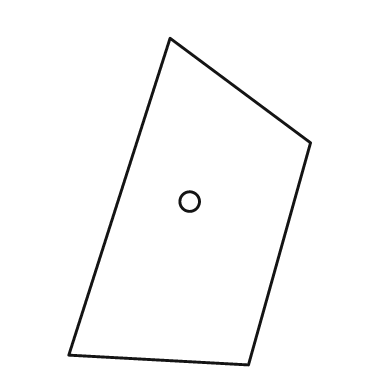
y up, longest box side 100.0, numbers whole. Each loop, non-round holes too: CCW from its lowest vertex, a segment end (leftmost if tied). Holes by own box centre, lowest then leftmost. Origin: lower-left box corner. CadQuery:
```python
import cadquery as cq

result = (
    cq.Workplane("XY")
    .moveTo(55.0, 0.0)
    .lineTo(74.0, 68.0)
    .lineTo(31.0, 100.0)
    .lineTo(0.0, 3.0)
    .close()
    .moveTo(37.0, 50.0)
    .circle(3.0)
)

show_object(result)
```